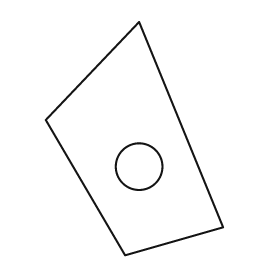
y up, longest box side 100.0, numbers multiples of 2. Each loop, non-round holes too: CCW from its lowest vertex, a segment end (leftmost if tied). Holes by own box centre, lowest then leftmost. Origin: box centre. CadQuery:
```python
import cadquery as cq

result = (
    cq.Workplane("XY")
    .moveTo(-4.0, -50.0)
    .lineTo(38.0, -38.0)
    .lineTo(2.0, 50.0)
    .lineTo(-38.0, 8.0)
    .close()
    .moveTo(2.0, -12.0)
    .circle(10.0)
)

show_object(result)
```